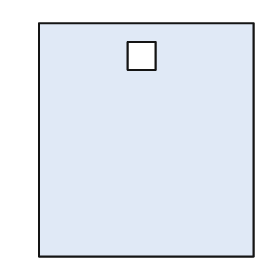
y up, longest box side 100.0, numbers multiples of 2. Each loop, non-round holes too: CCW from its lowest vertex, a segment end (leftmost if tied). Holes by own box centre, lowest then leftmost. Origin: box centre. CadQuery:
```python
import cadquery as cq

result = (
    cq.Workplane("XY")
    .moveTo(-46.0, -50.0)
    .lineTo(46.0, -50.0)
    .lineTo(46.0, 50.0)
    .lineTo(-46.0, 50.0)
    .close()
    .moveTo(-8.0, 30.0)
    .lineTo(4.0, 30.0)
    .lineTo(4.0, 42.0)
    .lineTo(-8.0, 42.0)
    .close()
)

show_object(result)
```